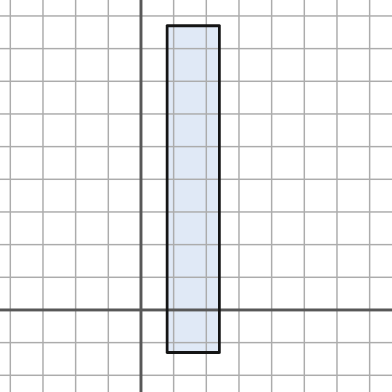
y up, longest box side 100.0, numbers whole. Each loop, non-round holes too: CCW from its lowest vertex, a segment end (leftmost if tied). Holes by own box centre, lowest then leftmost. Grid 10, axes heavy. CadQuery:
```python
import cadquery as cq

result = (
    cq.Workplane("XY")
    .moveTo(8.0, -13.0)
    .lineTo(24.0, -13.0)
    .lineTo(24.0, 87.0)
    .lineTo(8.0, 87.0)
    .close()
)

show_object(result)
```